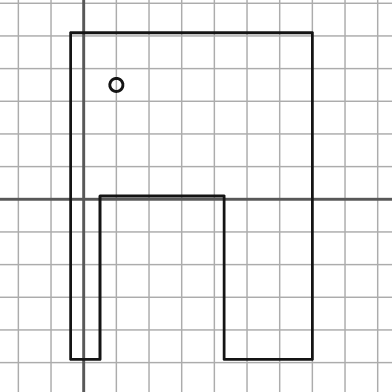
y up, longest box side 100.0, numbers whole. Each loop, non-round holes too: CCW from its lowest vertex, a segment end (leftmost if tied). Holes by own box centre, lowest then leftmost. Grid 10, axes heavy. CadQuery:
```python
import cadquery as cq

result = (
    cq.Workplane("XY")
    .moveTo(-4.0, -49.0)
    .lineTo(5.0, -49.0)
    .lineTo(5.0, 1.0)
    .lineTo(43.0, 1.0)
    .lineTo(43.0, -49.0)
    .lineTo(70.0, -49.0)
    .lineTo(70.0, 51.0)
    .lineTo(-4.0, 51.0)
    .close()
    .moveTo(10.0, 35.0)
    .circle(2.0)
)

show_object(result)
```